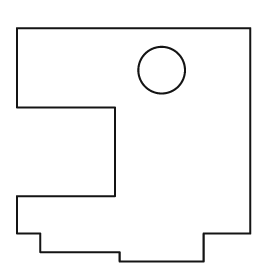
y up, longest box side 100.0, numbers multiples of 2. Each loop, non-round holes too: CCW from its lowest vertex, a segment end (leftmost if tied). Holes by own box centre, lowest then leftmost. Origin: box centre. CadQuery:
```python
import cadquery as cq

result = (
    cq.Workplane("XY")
    .moveTo(-6.0, -50.0)
    .lineTo(30.0, -50.0)
    .lineTo(30.0, -38.0)
    .lineTo(50.0, -38.0)
    .lineTo(50.0, 50.0)
    .lineTo(-50.0, 50.0)
    .lineTo(-50.0, 16.0)
    .lineTo(-8.0, 16.0)
    .lineTo(-8.0, -22.0)
    .lineTo(-50.0, -22.0)
    .lineTo(-50.0, -38.0)
    .lineTo(-40.0, -38.0)
    .lineTo(-40.0, -46.0)
    .lineTo(-6.0, -46.0)
    .close()
    .moveTo(12.0, 32.0)
    .circle(10.0)
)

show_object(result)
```